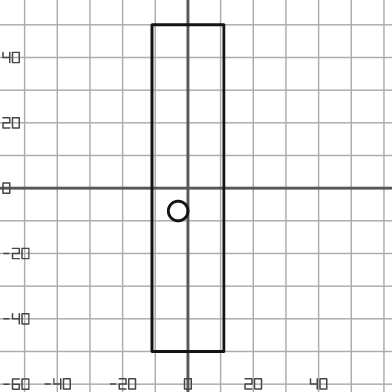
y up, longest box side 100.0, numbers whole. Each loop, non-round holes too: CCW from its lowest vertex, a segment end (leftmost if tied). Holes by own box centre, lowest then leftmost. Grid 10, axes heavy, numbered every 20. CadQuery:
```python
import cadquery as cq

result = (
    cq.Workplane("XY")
    .moveTo(-11.0, -50.0)
    .lineTo(11.0, -50.0)
    .lineTo(11.0, 50.0)
    .lineTo(-11.0, 50.0)
    .close()
    .moveTo(-3.0, -7.0)
    .circle(3.0)
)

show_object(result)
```